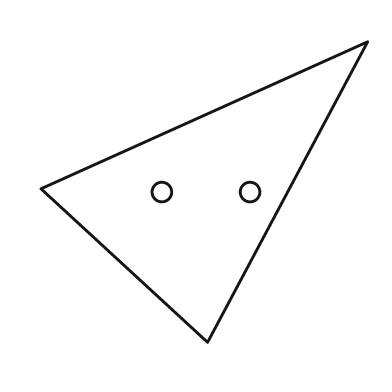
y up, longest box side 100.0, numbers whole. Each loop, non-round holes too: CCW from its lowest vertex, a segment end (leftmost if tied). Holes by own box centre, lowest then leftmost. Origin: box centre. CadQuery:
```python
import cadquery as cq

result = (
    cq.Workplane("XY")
    .moveTo(1.0, -46.0)
    .lineTo(50.0, 46.0)
    .lineTo(-50.0, 1.0)
    .close()
    .moveTo(-13.0, 0.0)
    .circle(3.0)
    .moveTo(14.0, 0.0)
    .circle(3.0)
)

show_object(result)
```